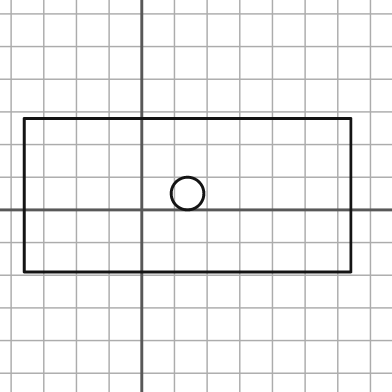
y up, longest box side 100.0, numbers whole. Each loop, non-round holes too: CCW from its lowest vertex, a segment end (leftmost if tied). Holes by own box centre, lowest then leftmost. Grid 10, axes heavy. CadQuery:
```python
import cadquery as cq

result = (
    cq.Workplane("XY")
    .moveTo(-36.0, -19.0)
    .lineTo(64.0, -19.0)
    .lineTo(64.0, 28.0)
    .lineTo(-36.0, 28.0)
    .close()
    .moveTo(14.0, 5.0)
    .circle(5.0)
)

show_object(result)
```